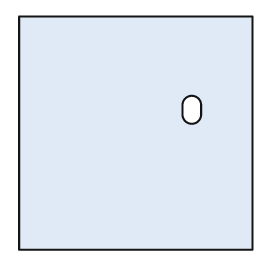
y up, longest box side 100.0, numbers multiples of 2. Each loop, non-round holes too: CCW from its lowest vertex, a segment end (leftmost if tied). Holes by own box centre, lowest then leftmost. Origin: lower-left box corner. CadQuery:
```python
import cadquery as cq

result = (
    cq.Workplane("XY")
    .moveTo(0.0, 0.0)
    .lineTo(100.0, 0.0)
    .lineTo(100.0, 100.0)
    .lineTo(0.0, 100.0)
    .close()
    .moveTo(70.0, 58.0)
    .threePointArc((74.0, 54.0), (78.0, 58.0))
    .lineTo(78.0, 62.0)
    .threePointArc((74.0, 66.0), (70.0, 62.0))
    .close()
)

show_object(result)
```